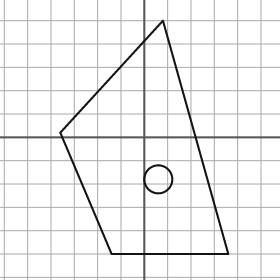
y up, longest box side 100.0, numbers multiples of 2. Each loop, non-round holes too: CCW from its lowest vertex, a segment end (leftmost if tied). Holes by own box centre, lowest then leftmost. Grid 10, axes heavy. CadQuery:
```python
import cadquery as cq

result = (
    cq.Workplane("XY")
    .moveTo(-14.0, -50.0)
    .lineTo(36.0, -50.0)
    .lineTo(8.0, 50.0)
    .lineTo(-36.0, 2.0)
    .close()
    .moveTo(6.0, -18.0)
    .circle(6.0)
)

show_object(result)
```